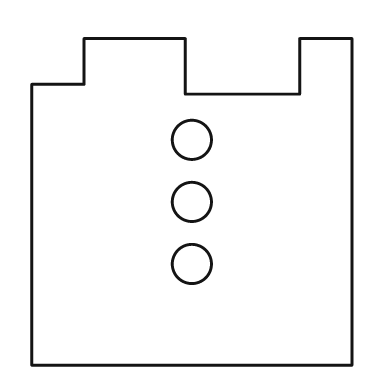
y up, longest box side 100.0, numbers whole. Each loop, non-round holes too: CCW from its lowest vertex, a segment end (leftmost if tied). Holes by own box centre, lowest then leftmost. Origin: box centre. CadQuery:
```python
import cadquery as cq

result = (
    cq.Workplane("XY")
    .moveTo(-49.0, -50.0)
    .lineTo(49.0, -50.0)
    .lineTo(49.0, 50.0)
    .lineTo(33.0, 50.0)
    .lineTo(33.0, 33.0)
    .lineTo(-2.0, 33.0)
    .lineTo(-2.0, 50.0)
    .lineTo(-33.0, 50.0)
    .lineTo(-33.0, 36.0)
    .lineTo(-49.0, 36.0)
    .close()
    .moveTo(0.0, -19.0)
    .circle(6.0)
    .moveTo(0.0, 0.0)
    .circle(6.0)
    .moveTo(0.0, 19.0)
    .circle(6.0)
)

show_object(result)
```